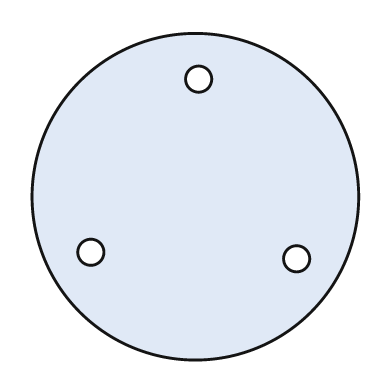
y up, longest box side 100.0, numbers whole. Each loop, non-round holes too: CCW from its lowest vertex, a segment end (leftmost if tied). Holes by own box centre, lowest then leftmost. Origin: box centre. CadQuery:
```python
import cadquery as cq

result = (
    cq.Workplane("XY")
    .moveTo(0.0, 0.0)
    .circle(50.0)
    .moveTo(31.0, -19.0)
    .circle(4.0)
    .moveTo(-32.0, -17.0)
    .circle(4.0)
    .moveTo(1.0, 36.0)
    .circle(4.0)
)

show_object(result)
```